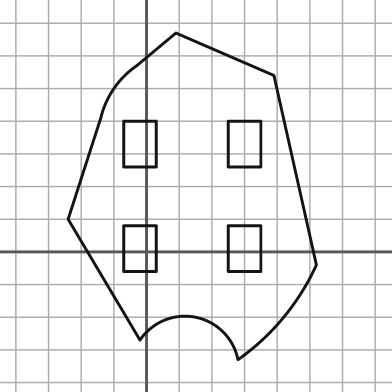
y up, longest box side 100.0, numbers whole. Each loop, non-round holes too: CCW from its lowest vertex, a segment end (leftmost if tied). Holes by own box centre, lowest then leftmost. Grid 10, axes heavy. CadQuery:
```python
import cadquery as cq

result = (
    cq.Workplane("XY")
    .moveTo(28.0, -33.0)
    .threePointArc((42.0, -20.0), (52.0, -4.0))
    .lineTo(39.0, 54.0)
    .lineTo(9.0, 67.0)
    .lineTo(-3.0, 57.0)
    .threePointArc((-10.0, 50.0), (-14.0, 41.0))
    .lineTo(-24.0, 10.0)
    .lineTo(-2.0, -27.0)
    .threePointArc((15.0, -20.0), (28.0, -33.0))
    .close()
    .moveTo(-7.0, -6.0)
    .lineTo(3.0, -6.0)
    .lineTo(3.0, 8.0)
    .lineTo(-7.0, 8.0)
    .close()
    .moveTo(25.0, -6.0)
    .lineTo(35.0, -6.0)
    .lineTo(35.0, 8.0)
    .lineTo(25.0, 8.0)
    .close()
    .moveTo(-7.0, 26.0)
    .lineTo(3.0, 26.0)
    .lineTo(3.0, 40.0)
    .lineTo(-7.0, 40.0)
    .close()
    .moveTo(25.0, 26.0)
    .lineTo(35.0, 26.0)
    .lineTo(35.0, 40.0)
    .lineTo(25.0, 40.0)
    .close()
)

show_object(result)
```